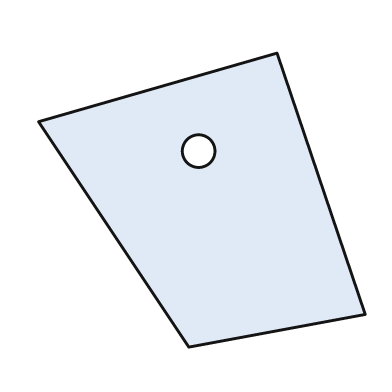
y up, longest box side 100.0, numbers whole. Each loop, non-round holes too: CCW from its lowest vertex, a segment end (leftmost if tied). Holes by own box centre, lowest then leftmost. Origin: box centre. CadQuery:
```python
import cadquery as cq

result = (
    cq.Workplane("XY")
    .moveTo(-4.0, -45.0)
    .lineTo(50.0, -35.0)
    .lineTo(23.0, 45.0)
    .lineTo(-50.0, 24.0)
    .close()
    .moveTo(-1.0, 15.0)
    .circle(5.0)
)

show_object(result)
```